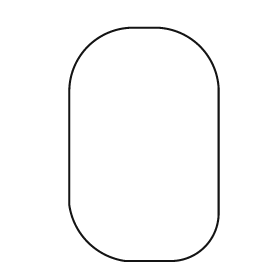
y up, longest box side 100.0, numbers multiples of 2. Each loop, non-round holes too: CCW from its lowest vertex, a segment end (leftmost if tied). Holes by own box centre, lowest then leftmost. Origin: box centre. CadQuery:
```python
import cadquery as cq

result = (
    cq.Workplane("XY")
    .moveTo(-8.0, -50.0)
    .lineTo(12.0, -50.0)
    .threePointArc((26.0, -44.0), (32.0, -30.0))
    .lineTo(32.0, 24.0)
    .threePointArc((24.0, 42.0), (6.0, 50.0))
    .lineTo(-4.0, 50.0)
    .threePointArc((-24.0, 42.0), (-32.0, 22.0))
    .lineTo(-32.0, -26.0)
    .threePointArc((-24.0, -42.0), (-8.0, -50.0))
    .close()
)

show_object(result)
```